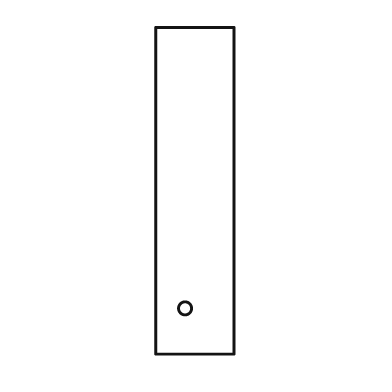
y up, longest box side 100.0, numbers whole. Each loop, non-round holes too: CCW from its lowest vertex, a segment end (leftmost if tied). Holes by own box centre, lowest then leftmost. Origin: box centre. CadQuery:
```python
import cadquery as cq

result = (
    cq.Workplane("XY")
    .moveTo(-12.0, -50.0)
    .lineTo(12.0, -50.0)
    .lineTo(12.0, 50.0)
    .lineTo(-12.0, 50.0)
    .close()
    .moveTo(-3.0, -36.0)
    .circle(2.0)
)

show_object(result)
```